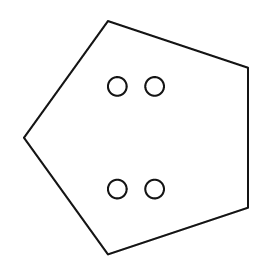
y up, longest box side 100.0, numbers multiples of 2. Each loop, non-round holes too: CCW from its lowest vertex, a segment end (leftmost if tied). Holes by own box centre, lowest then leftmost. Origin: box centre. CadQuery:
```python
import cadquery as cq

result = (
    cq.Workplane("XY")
    .moveTo(-12.0, -50.0)
    .lineTo(48.0, -30.0)
    .lineTo(48.0, 30.0)
    .lineTo(-12.0, 50.0)
    .lineTo(-48.0, 0.0)
    .close()
    .moveTo(-8.0, -22.0)
    .circle(4.0)
    .moveTo(8.0, -22.0)
    .circle(4.0)
    .moveTo(-8.0, 22.0)
    .circle(4.0)
    .moveTo(8.0, 22.0)
    .circle(4.0)
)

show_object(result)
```